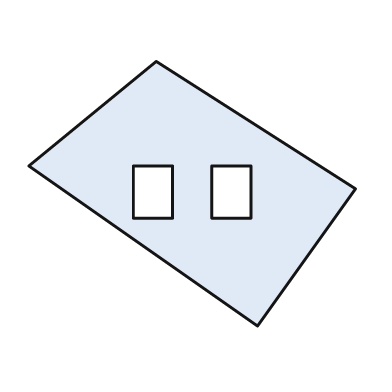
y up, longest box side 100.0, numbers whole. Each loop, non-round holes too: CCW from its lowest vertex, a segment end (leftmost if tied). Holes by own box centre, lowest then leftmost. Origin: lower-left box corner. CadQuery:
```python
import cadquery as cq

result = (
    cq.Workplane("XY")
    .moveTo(70.0, 0.0)
    .lineTo(100.0, 42.0)
    .lineTo(39.0, 81.0)
    .lineTo(0.0, 49.0)
    .close()
    .moveTo(32.0, 33.0)
    .lineTo(44.0, 33.0)
    .lineTo(44.0, 49.0)
    .lineTo(32.0, 49.0)
    .close()
    .moveTo(56.0, 33.0)
    .lineTo(68.0, 33.0)
    .lineTo(68.0, 49.0)
    .lineTo(56.0, 49.0)
    .close()
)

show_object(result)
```